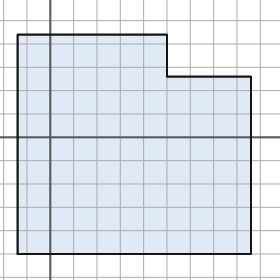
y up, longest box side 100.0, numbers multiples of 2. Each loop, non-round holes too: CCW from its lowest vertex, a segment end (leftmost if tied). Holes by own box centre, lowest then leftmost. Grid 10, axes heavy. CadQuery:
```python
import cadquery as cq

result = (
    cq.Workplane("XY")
    .moveTo(-14.0, -50.0)
    .lineTo(86.0, -50.0)
    .lineTo(86.0, 26.0)
    .lineTo(50.0, 26.0)
    .lineTo(50.0, 44.0)
    .lineTo(-14.0, 44.0)
    .close()
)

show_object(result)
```